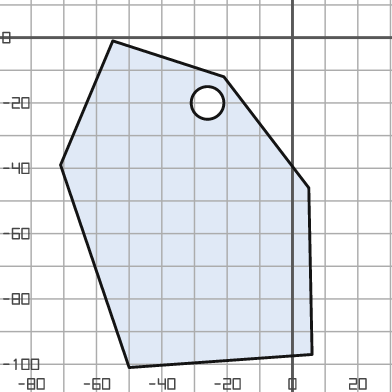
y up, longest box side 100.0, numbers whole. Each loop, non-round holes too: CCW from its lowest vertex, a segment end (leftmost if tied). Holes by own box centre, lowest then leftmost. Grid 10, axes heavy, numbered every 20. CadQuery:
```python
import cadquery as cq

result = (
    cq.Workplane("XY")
    .moveTo(-50.0, -101.0)
    .lineTo(6.0, -97.0)
    .lineTo(5.0, -46.0)
    .lineTo(-21.0, -12.0)
    .lineTo(-55.0, -1.0)
    .lineTo(-71.0, -39.0)
    .close()
    .moveTo(-26.0, -20.0)
    .circle(5.0)
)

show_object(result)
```